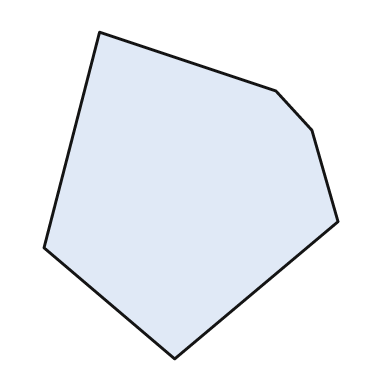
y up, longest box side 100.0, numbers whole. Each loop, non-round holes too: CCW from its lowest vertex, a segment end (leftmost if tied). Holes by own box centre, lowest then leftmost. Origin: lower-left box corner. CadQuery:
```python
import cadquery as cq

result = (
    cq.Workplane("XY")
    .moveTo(40.0, 0.0)
    .lineTo(90.0, 42.0)
    .lineTo(82.0, 70.0)
    .lineTo(71.0, 82.0)
    .lineTo(17.0, 100.0)
    .lineTo(0.0, 34.0)
    .close()
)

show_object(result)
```